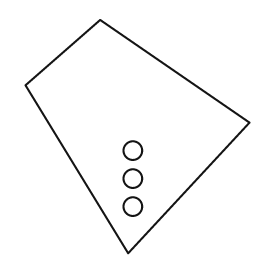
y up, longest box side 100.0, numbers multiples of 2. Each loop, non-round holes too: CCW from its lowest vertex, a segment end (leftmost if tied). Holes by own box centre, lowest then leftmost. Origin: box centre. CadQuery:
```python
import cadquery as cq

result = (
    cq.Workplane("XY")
    .moveTo(-4.0, -50.0)
    .lineTo(48.0, 6.0)
    .lineTo(-16.0, 50.0)
    .lineTo(-48.0, 22.0)
    .close()
    .moveTo(-2.0, -30.0)
    .circle(4.0)
    .moveTo(-2.0, -18.0)
    .circle(4.0)
    .moveTo(-2.0, -6.0)
    .circle(4.0)
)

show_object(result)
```